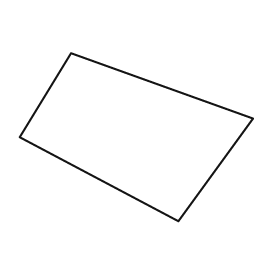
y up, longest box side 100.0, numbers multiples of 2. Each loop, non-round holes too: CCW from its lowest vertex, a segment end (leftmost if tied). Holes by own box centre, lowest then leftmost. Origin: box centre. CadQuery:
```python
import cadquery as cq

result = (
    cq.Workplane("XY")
    .moveTo(18.0, -36.0)
    .lineTo(50.0, 8.0)
    .lineTo(-28.0, 36.0)
    .lineTo(-50.0, 0.0)
    .close()
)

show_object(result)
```